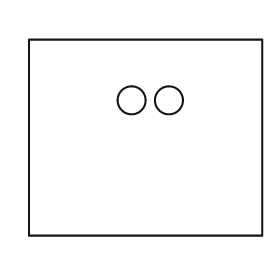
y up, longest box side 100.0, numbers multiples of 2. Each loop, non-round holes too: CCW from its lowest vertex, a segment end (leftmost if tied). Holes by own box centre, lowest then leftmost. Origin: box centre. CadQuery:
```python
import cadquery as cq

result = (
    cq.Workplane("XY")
    .moveTo(-50.0, -42.0)
    .lineTo(50.0, -42.0)
    .lineTo(50.0, 42.0)
    .lineTo(-50.0, 42.0)
    .close()
    .moveTo(-6.0, 16.0)
    .circle(6.0)
    .moveTo(10.0, 16.0)
    .circle(6.0)
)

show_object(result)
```